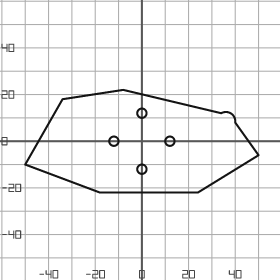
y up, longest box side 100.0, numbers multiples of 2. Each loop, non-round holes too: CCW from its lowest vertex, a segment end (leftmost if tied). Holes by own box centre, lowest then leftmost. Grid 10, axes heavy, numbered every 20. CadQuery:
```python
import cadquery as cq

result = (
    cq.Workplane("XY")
    .moveTo(-18.0, -22.0)
    .lineTo(24.0, -22.0)
    .lineTo(50.0, -6.0)
    .lineTo(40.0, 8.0)
    .threePointArc((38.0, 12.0), (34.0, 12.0))
    .lineTo(-8.0, 22.0)
    .lineTo(-34.0, 18.0)
    .lineTo(-50.0, -10.0)
    .close()
    .moveTo(0.0, -12.0)
    .circle(2.0)
    .moveTo(-12.0, 0.0)
    .circle(2.0)
    .moveTo(12.0, 0.0)
    .circle(2.0)
    .moveTo(0.0, 12.0)
    .circle(2.0)
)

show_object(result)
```